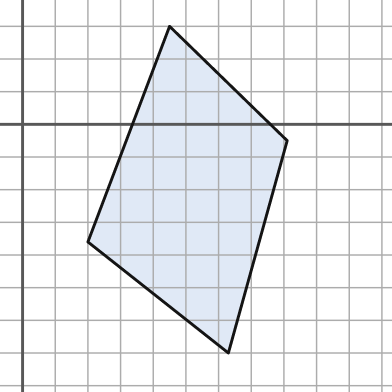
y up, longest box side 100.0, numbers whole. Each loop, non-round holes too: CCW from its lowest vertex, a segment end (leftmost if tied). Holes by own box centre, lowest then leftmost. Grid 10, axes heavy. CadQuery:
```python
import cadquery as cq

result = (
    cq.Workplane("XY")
    .moveTo(63.0, -70.0)
    .lineTo(81.0, -5.0)
    .lineTo(45.0, 30.0)
    .lineTo(20.0, -36.0)
    .close()
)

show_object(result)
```